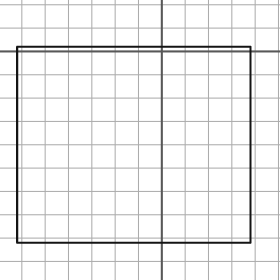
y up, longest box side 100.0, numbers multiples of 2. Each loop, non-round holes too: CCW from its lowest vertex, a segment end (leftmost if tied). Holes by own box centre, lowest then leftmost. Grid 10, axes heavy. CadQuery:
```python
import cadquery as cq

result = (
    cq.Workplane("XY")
    .moveTo(-62.0, -82.0)
    .lineTo(38.0, -82.0)
    .lineTo(38.0, 2.0)
    .lineTo(-62.0, 2.0)
    .close()
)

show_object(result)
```